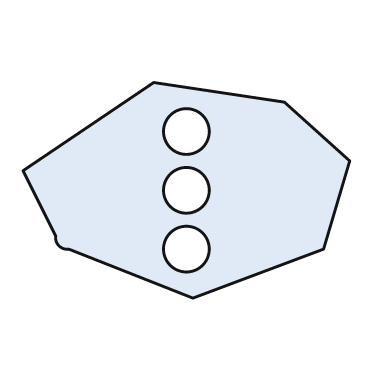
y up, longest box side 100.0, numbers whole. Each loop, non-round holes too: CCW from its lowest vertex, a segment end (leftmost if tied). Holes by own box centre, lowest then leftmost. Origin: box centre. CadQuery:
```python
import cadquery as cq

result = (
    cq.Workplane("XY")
    .moveTo(2.0, -33.0)
    .lineTo(42.0, -18.0)
    .lineTo(50.0, 9.0)
    .lineTo(30.0, 27.0)
    .lineTo(-10.0, 33.0)
    .lineTo(-50.0, 6.0)
    .lineTo(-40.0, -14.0)
    .threePointArc((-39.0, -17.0), (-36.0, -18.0))
    .close()
    .moveTo(0.0, -18.0)
    .circle(7.0)
    .moveTo(0.0, 0.0)
    .circle(7.0)
    .moveTo(0.0, 18.0)
    .circle(7.0)
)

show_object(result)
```